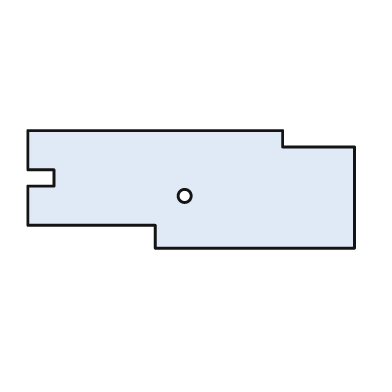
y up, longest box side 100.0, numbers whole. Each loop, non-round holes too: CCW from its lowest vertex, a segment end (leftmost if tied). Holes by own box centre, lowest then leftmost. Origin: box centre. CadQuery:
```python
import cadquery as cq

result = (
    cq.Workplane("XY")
    .moveTo(-11.0, -18.0)
    .lineTo(50.0, -18.0)
    .lineTo(50.0, 13.0)
    .lineTo(28.0, 13.0)
    .lineTo(28.0, 18.0)
    .lineTo(-50.0, 18.0)
    .lineTo(-50.0, 6.0)
    .lineTo(-42.0, 6.0)
    .lineTo(-42.0, 1.0)
    .lineTo(-50.0, 1.0)
    .lineTo(-50.0, -11.0)
    .lineTo(-11.0, -11.0)
    .close()
    .moveTo(-2.0, -2.0)
    .circle(2.0)
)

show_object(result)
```